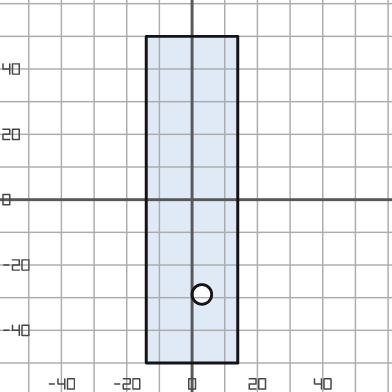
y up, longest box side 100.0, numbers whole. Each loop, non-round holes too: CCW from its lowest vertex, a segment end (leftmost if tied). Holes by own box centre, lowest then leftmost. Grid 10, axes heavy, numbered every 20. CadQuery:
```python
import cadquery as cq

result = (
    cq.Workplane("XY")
    .moveTo(-14.0, -50.0)
    .lineTo(14.0, -50.0)
    .lineTo(14.0, 50.0)
    .lineTo(-14.0, 50.0)
    .close()
    .moveTo(3.0, -29.0)
    .circle(3.0)
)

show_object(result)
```